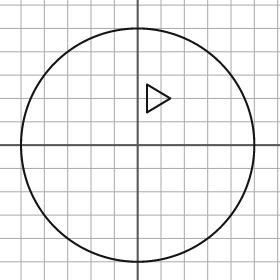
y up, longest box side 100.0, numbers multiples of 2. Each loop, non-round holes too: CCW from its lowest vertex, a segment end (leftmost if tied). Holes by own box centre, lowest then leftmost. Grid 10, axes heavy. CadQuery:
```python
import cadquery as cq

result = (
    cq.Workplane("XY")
    .moveTo(0.0, 0.0)
    .circle(50.0)
    .moveTo(4.0, 14.0)
    .lineTo(14.0, 20.0)
    .lineTo(4.0, 26.0)
    .close()
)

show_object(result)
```